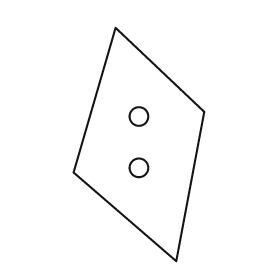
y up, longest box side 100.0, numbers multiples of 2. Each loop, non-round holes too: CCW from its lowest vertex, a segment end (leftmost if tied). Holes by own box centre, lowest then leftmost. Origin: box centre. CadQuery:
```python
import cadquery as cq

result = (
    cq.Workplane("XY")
    .moveTo(16.0, -50.0)
    .lineTo(28.0, 14.0)
    .lineTo(-10.0, 50.0)
    .lineTo(-28.0, -12.0)
    .close()
    .moveTo(0.0, -10.0)
    .circle(4.0)
    .moveTo(0.0, 12.0)
    .circle(4.0)
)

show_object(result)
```